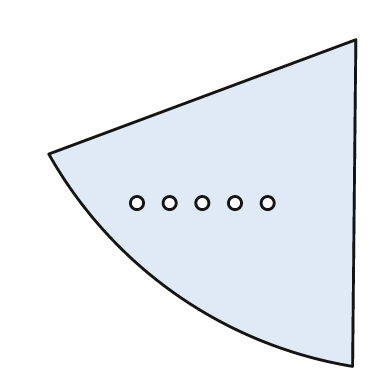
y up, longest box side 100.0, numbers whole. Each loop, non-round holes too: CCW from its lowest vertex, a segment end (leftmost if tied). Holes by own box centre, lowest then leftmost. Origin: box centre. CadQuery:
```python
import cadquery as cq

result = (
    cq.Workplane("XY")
    .moveTo(46.0, -50.0)
    .lineTo(47.0, 50.0)
    .lineTo(-47.0, 15.0)
    .threePointArc((-8.0, -28.0), (46.0, -50.0))
    .close()
    .moveTo(-20.0, 0.0)
    .circle(2.0)
    .moveTo(-10.0, 0.0)
    .circle(2.0)
    .moveTo(0.0, 0.0)
    .circle(2.0)
    .moveTo(10.0, 0.0)
    .circle(2.0)
    .moveTo(20.0, 0.0)
    .circle(2.0)
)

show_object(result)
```